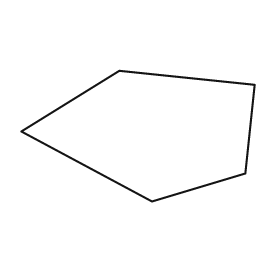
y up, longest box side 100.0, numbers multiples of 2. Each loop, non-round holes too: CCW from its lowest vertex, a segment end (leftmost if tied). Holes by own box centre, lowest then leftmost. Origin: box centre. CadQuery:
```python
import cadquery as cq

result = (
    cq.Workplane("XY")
    .moveTo(6.0, -28.0)
    .lineTo(46.0, -16.0)
    .lineTo(50.0, 22.0)
    .lineTo(-8.0, 28.0)
    .lineTo(-50.0, 2.0)
    .close()
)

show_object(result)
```